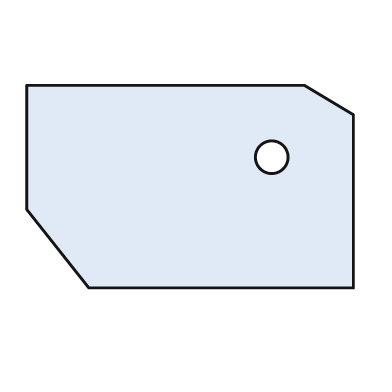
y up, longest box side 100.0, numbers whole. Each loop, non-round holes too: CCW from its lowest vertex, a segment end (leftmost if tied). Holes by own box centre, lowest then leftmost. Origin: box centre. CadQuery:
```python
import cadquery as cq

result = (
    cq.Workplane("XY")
    .moveTo(-31.0, -31.0)
    .lineTo(50.0, -31.0)
    .lineTo(50.0, 22.0)
    .lineTo(35.0, 31.0)
    .lineTo(-50.0, 31.0)
    .lineTo(-50.0, -7.0)
    .close()
    .moveTo(25.0, 9.0)
    .circle(5.0)
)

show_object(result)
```